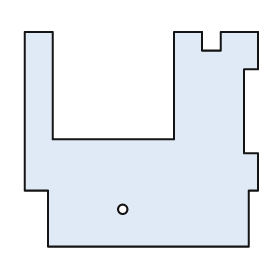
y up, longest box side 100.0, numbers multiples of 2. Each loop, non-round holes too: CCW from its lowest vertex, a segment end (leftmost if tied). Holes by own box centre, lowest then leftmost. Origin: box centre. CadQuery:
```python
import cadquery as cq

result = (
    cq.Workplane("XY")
    .moveTo(-40.0, -46.0)
    .lineTo(46.0, -46.0)
    .lineTo(46.0, -22.0)
    .lineTo(50.0, -22.0)
    .lineTo(50.0, -6.0)
    .lineTo(44.0, -6.0)
    .lineTo(44.0, 30.0)
    .lineTo(50.0, 30.0)
    .lineTo(50.0, 46.0)
    .lineTo(34.0, 46.0)
    .lineTo(34.0, 38.0)
    .lineTo(26.0, 38.0)
    .lineTo(26.0, 46.0)
    .lineTo(14.0, 46.0)
    .lineTo(14.0, 0.0)
    .lineTo(-38.0, 0.0)
    .lineTo(-38.0, 46.0)
    .lineTo(-50.0, 46.0)
    .lineTo(-50.0, -22.0)
    .lineTo(-40.0, -22.0)
    .close()
    .moveTo(-8.0, -30.0)
    .circle(2.0)
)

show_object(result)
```